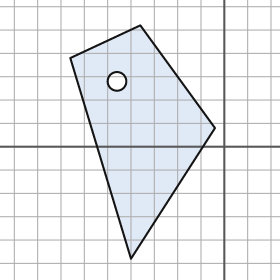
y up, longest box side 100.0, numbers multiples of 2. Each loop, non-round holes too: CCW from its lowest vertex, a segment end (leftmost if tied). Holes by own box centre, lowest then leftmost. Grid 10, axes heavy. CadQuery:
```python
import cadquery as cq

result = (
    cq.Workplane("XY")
    .moveTo(-40.0, -48.0)
    .lineTo(-4.0, 8.0)
    .lineTo(-36.0, 52.0)
    .lineTo(-66.0, 38.0)
    .close()
    .moveTo(-46.0, 28.0)
    .circle(4.0)
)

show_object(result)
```